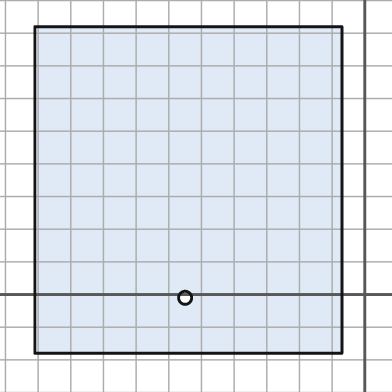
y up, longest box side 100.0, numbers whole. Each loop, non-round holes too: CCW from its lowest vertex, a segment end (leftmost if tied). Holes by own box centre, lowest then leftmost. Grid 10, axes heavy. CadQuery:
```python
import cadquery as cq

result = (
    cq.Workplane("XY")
    .moveTo(-101.0, -18.0)
    .lineTo(-7.0, -18.0)
    .lineTo(-7.0, 82.0)
    .lineTo(-101.0, 82.0)
    .close()
    .moveTo(-55.0, -1.0)
    .circle(2.0)
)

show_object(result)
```